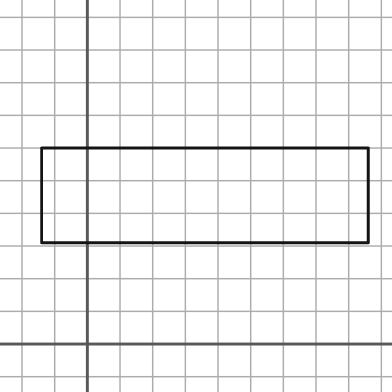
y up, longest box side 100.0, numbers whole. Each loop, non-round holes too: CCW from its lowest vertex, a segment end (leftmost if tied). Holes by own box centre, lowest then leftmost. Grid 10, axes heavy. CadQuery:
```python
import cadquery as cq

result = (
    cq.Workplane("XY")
    .moveTo(-14.0, 31.0)
    .lineTo(86.0, 31.0)
    .lineTo(86.0, 60.0)
    .lineTo(-14.0, 60.0)
    .close()
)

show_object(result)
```